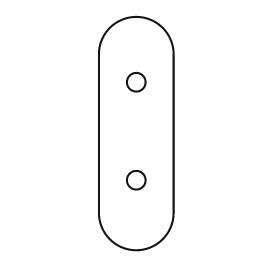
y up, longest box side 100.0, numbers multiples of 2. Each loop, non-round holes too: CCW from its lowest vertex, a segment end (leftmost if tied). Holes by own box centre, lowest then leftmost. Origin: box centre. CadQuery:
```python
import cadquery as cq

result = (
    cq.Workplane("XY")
    .moveTo(-16.0, -34.0)
    .threePointArc((0.0, -50.0), (16.0, -34.0))
    .lineTo(16.0, 34.0)
    .threePointArc((0.0, 50.0), (-16.0, 34.0))
    .close()
    .moveTo(0.0, -20.0)
    .circle(4.0)
    .moveTo(0.0, 22.0)
    .circle(4.0)
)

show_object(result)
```